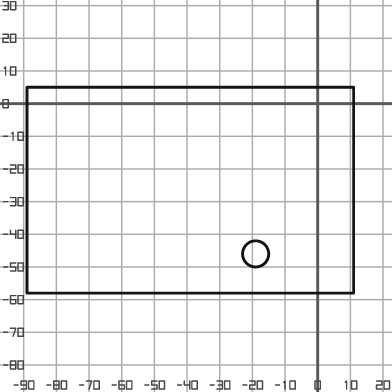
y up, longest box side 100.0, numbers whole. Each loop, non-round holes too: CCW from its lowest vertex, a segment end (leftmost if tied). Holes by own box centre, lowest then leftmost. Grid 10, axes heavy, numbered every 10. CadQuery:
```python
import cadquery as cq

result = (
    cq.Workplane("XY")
    .moveTo(-89.0, -58.0)
    .lineTo(11.0, -58.0)
    .lineTo(11.0, 5.0)
    .lineTo(-89.0, 5.0)
    .close()
    .moveTo(-19.0, -46.0)
    .circle(4.0)
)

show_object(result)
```